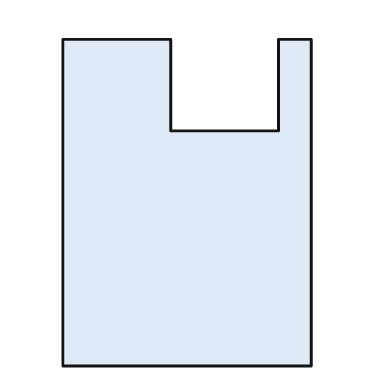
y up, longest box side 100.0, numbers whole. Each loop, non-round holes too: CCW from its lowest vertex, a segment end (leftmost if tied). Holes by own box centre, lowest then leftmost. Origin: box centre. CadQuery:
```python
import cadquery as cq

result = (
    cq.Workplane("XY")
    .moveTo(-38.0, -50.0)
    .lineTo(38.0, -50.0)
    .lineTo(38.0, 50.0)
    .lineTo(28.0, 50.0)
    .lineTo(28.0, 22.0)
    .lineTo(-5.0, 22.0)
    .lineTo(-5.0, 50.0)
    .lineTo(-38.0, 50.0)
    .close()
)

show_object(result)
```